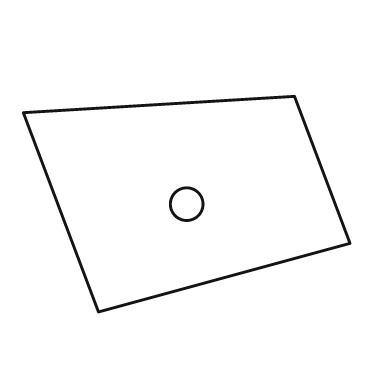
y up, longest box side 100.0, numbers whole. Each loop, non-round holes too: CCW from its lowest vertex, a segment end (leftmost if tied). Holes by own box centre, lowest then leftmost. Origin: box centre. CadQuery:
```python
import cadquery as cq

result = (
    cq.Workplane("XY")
    .moveTo(-27.0, -33.0)
    .lineTo(50.0, -12.0)
    .lineTo(33.0, 33.0)
    .lineTo(-50.0, 28.0)
    .close()
    .moveTo(0.0, 0.0)
    .circle(5.0)
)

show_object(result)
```